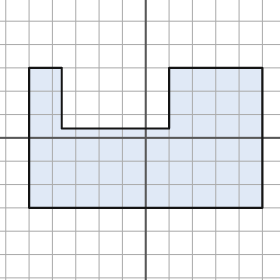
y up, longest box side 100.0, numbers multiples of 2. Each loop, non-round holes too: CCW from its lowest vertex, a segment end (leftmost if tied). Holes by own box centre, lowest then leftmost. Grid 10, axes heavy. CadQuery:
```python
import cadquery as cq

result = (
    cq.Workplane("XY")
    .moveTo(-50.0, -30.0)
    .lineTo(50.0, -30.0)
    .lineTo(50.0, 30.0)
    .lineTo(10.0, 30.0)
    .lineTo(10.0, 4.0)
    .lineTo(-36.0, 4.0)
    .lineTo(-36.0, 30.0)
    .lineTo(-50.0, 30.0)
    .close()
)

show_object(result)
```